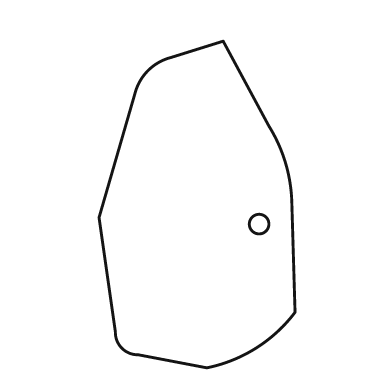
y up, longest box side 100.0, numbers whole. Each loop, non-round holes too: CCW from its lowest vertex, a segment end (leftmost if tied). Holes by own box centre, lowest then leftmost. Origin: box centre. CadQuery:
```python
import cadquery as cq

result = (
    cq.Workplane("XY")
    .moveTo(3.0, -50.0)
    .threePointArc((18.0, -44.0), (30.0, -33.0))
    .lineTo(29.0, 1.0)
    .threePointArc((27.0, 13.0), (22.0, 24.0))
    .lineTo(8.0, 50.0)
    .lineTo(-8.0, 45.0)
    .threePointArc((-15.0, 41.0), (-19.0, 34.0))
    .lineTo(-30.0, -4.0)
    .lineTo(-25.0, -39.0)
    .threePointArc((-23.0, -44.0), (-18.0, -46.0))
    .close()
    .moveTo(19.0, -6.0)
    .circle(3.0)
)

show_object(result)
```